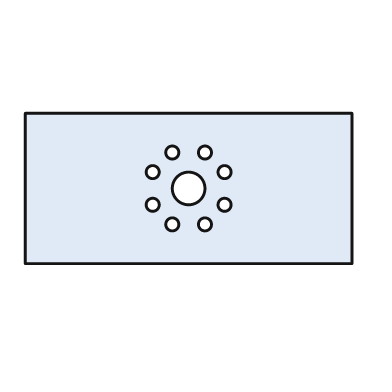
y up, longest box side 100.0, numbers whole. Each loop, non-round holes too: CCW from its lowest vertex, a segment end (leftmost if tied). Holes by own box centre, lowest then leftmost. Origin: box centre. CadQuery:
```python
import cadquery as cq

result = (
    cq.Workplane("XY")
    .moveTo(-50.0, -23.0)
    .lineTo(50.0, -23.0)
    .lineTo(50.0, 23.0)
    .lineTo(-50.0, 23.0)
    .close()
    .moveTo(-5.0, -11.0)
    .circle(2.0)
    .moveTo(5.0, -11.0)
    .circle(2.0)
    .moveTo(-11.0, -5.0)
    .circle(2.0)
    .moveTo(11.0, -5.0)
    .circle(2.0)
    .moveTo(0.0, 0.0)
    .circle(5.0)
    .moveTo(-11.0, 5.0)
    .circle(2.0)
    .moveTo(11.0, 5.0)
    .circle(2.0)
    .moveTo(-5.0, 11.0)
    .circle(2.0)
    .moveTo(5.0, 11.0)
    .circle(2.0)
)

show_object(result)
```